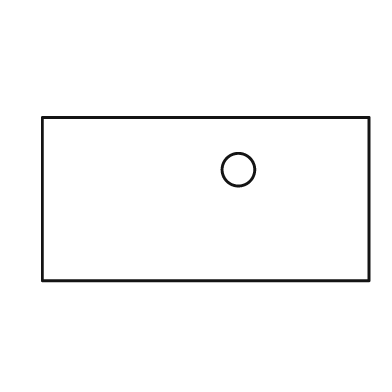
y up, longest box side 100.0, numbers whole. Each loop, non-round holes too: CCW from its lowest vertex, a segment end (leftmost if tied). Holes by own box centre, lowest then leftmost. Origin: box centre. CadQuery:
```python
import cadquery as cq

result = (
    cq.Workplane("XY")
    .moveTo(-50.0, -25.0)
    .lineTo(50.0, -25.0)
    .lineTo(50.0, 25.0)
    .lineTo(-50.0, 25.0)
    .close()
    .moveTo(10.0, 9.0)
    .circle(5.0)
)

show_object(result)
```